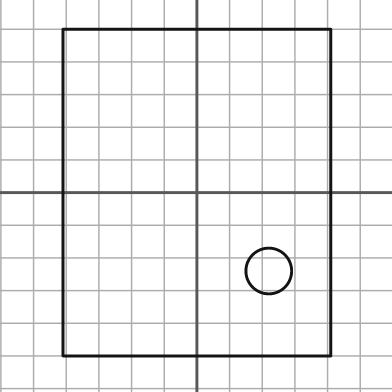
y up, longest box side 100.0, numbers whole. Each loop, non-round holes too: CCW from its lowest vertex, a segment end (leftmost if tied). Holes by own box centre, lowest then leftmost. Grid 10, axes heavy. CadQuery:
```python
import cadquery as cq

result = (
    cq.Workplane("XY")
    .moveTo(-41.0, -50.0)
    .lineTo(41.0, -50.0)
    .lineTo(41.0, 50.0)
    .lineTo(-41.0, 50.0)
    .close()
    .moveTo(22.0, -24.0)
    .circle(7.0)
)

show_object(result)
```